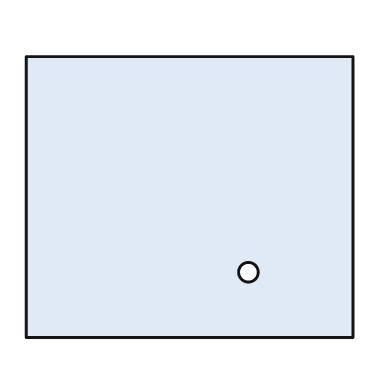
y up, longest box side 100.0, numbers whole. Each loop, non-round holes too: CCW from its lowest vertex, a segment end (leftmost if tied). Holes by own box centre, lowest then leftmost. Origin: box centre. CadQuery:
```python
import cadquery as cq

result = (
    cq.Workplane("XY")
    .moveTo(-50.0, -43.0)
    .lineTo(50.0, -43.0)
    .lineTo(50.0, 43.0)
    .lineTo(-50.0, 43.0)
    .close()
    .moveTo(18.0, -23.0)
    .circle(3.0)
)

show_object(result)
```